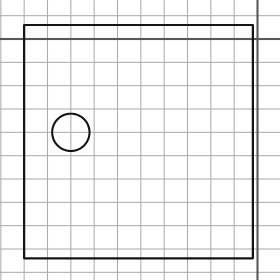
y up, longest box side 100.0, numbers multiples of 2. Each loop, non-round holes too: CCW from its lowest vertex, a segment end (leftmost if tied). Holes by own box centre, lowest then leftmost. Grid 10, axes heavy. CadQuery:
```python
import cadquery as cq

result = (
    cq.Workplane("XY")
    .moveTo(-100.0, -94.0)
    .lineTo(-2.0, -94.0)
    .lineTo(-2.0, 6.0)
    .lineTo(-100.0, 6.0)
    .close()
    .moveTo(-80.0, -40.0)
    .circle(8.0)
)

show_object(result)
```